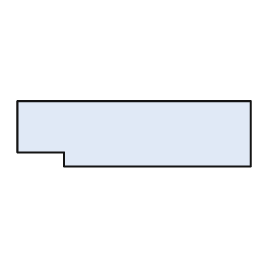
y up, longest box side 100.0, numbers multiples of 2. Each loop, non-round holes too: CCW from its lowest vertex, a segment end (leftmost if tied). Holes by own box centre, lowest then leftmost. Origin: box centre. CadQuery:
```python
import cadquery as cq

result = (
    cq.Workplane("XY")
    .moveTo(-30.0, -14.0)
    .lineTo(50.0, -14.0)
    .lineTo(50.0, 14.0)
    .lineTo(-50.0, 14.0)
    .lineTo(-50.0, -8.0)
    .lineTo(-30.0, -8.0)
    .close()
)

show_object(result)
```